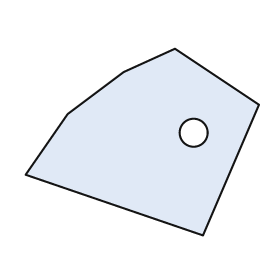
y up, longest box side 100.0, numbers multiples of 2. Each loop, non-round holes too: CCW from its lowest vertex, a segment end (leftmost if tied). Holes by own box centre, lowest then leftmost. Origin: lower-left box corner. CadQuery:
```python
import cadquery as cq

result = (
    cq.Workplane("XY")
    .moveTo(76.0, 0.0)
    .lineTo(100.0, 56.0)
    .lineTo(64.0, 80.0)
    .lineTo(42.0, 70.0)
    .lineTo(18.0, 52.0)
    .lineTo(0.0, 26.0)
    .close()
    .moveTo(72.0, 44.0)
    .circle(6.0)
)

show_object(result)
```